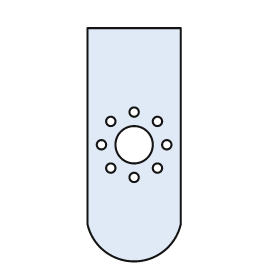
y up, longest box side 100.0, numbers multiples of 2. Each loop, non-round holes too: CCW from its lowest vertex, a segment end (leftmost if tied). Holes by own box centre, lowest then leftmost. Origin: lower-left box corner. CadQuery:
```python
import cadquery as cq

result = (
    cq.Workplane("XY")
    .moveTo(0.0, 16.0)
    .threePointArc((20.0, 0.0), (40.0, 16.0))
    .lineTo(40.0, 100.0)
    .lineTo(0.0, 100.0)
    .close()
    .moveTo(20.0, 36.0)
    .circle(2.0)
    .moveTo(10.0, 40.0)
    .circle(2.0)
    .moveTo(30.0, 40.0)
    .circle(2.0)
    .moveTo(6.0, 50.0)
    .circle(2.0)
    .moveTo(20.0, 50.0)
    .circle(8.0)
    .moveTo(34.0, 50.0)
    .circle(2.0)
    .moveTo(10.0, 60.0)
    .circle(2.0)
    .moveTo(30.0, 60.0)
    .circle(2.0)
    .moveTo(20.0, 64.0)
    .circle(2.0)
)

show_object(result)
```